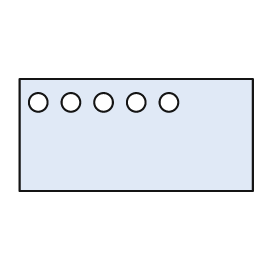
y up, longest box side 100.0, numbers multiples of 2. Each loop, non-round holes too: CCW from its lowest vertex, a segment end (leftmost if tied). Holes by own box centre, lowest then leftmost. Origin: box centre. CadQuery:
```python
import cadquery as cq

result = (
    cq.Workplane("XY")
    .moveTo(-50.0, -24.0)
    .lineTo(50.0, -24.0)
    .lineTo(50.0, 24.0)
    .lineTo(-50.0, 24.0)
    .close()
    .moveTo(-42.0, 14.0)
    .circle(4.0)
    .moveTo(-28.0, 14.0)
    .circle(4.0)
    .moveTo(-14.0, 14.0)
    .circle(4.0)
    .moveTo(0.0, 14.0)
    .circle(4.0)
    .moveTo(14.0, 14.0)
    .circle(4.0)
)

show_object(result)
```